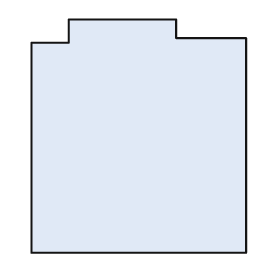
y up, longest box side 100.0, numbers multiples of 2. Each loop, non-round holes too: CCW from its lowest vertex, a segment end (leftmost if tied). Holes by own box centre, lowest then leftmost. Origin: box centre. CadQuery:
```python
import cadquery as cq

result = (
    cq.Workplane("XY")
    .moveTo(-46.0, -50.0)
    .lineTo(46.0, -50.0)
    .lineTo(46.0, 42.0)
    .lineTo(16.0, 42.0)
    .lineTo(16.0, 50.0)
    .lineTo(-30.0, 50.0)
    .lineTo(-30.0, 40.0)
    .lineTo(-46.0, 40.0)
    .close()
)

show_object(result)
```